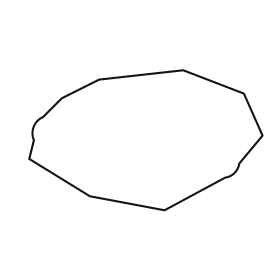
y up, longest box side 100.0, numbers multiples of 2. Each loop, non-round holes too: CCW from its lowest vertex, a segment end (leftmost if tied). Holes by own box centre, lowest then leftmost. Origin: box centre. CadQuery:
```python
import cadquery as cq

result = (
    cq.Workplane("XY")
    .moveTo(8.0, -30.0)
    .lineTo(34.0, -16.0)
    .threePointArc((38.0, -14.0), (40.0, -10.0))
    .lineTo(50.0, 2.0)
    .lineTo(42.0, 20.0)
    .lineTo(16.0, 30.0)
    .lineTo(-20.0, 26.0)
    .lineTo(-36.0, 18.0)
    .lineTo(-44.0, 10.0)
    .threePointArc((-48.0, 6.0), (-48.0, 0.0))
    .lineTo(-50.0, -8.0)
    .lineTo(-24.0, -24.0)
    .close()
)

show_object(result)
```